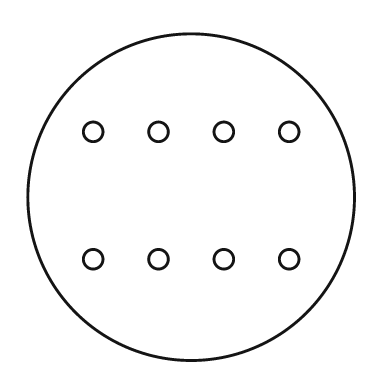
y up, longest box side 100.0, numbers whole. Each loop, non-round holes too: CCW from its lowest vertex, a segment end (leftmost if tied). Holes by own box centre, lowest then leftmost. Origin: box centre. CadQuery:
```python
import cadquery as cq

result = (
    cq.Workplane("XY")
    .moveTo(0.0, 0.0)
    .circle(50.0)
    .moveTo(-30.0, -19.0)
    .circle(3.0)
    .moveTo(-10.0, -19.0)
    .circle(3.0)
    .moveTo(10.0, -19.0)
    .circle(3.0)
    .moveTo(30.0, -19.0)
    .circle(3.0)
    .moveTo(-30.0, 20.0)
    .circle(3.0)
    .moveTo(-10.0, 20.0)
    .circle(3.0)
    .moveTo(10.0, 20.0)
    .circle(3.0)
    .moveTo(30.0, 20.0)
    .circle(3.0)
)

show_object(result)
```